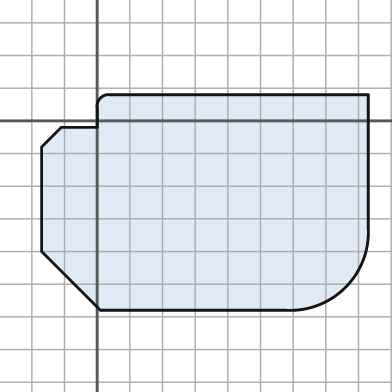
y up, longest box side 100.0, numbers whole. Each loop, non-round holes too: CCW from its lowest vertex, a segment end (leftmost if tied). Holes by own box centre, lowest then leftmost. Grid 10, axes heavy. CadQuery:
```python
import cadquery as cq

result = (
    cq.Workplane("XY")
    .moveTo(1.0, -58.0)
    .lineTo(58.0, -58.0)
    .threePointArc((76.0, -51.0), (83.0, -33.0))
    .lineTo(83.0, 8.0)
    .lineTo(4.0, 8.0)
    .threePointArc((1.0, 7.0), (0.0, 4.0))
    .lineTo(0.0, -2.0)
    .lineTo(-11.0, -2.0)
    .lineTo(-17.0, -8.0)
    .lineTo(-17.0, -40.0)
    .close()
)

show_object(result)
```